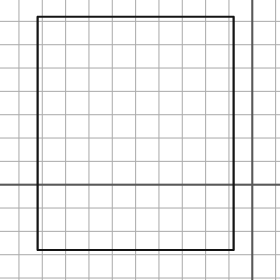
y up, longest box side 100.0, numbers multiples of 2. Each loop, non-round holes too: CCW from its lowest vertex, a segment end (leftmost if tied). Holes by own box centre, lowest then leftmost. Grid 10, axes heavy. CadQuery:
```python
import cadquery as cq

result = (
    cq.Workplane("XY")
    .moveTo(-92.0, -28.0)
    .lineTo(-8.0, -28.0)
    .lineTo(-8.0, 72.0)
    .lineTo(-92.0, 72.0)
    .close()
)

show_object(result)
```